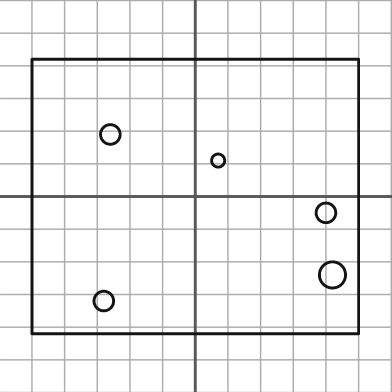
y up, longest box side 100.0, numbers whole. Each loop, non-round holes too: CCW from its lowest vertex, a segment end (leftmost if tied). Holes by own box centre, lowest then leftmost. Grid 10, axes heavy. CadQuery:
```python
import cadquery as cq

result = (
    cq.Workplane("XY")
    .moveTo(-50.0, -42.0)
    .lineTo(50.0, -42.0)
    .lineTo(50.0, 42.0)
    .lineTo(-50.0, 42.0)
    .close()
    .moveTo(-28.0, -32.0)
    .circle(3.0)
    .moveTo(42.0, -24.0)
    .circle(4.0)
    .moveTo(40.0, -5.0)
    .circle(3.0)
    .moveTo(7.0, 11.0)
    .circle(2.0)
    .moveTo(-26.0, 19.0)
    .circle(3.0)
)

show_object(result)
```